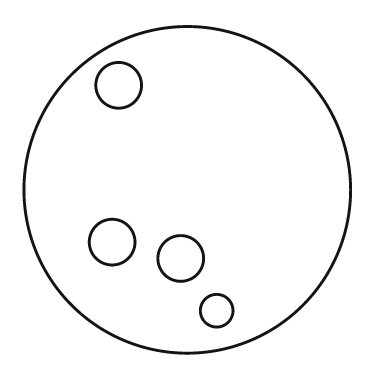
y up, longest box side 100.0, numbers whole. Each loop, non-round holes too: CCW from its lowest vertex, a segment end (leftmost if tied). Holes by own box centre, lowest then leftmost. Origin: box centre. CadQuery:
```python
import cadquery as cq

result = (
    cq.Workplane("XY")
    .moveTo(0.0, 0.0)
    .circle(50.0)
    .moveTo(9.0, -37.0)
    .circle(5.0)
    .moveTo(-2.0, -21.0)
    .circle(7.0)
    .moveTo(-23.0, -16.0)
    .circle(7.0)
    .moveTo(-21.0, 32.0)
    .circle(7.0)
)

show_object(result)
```